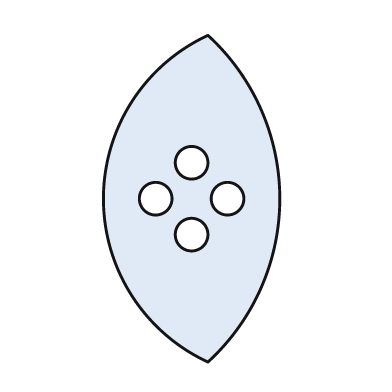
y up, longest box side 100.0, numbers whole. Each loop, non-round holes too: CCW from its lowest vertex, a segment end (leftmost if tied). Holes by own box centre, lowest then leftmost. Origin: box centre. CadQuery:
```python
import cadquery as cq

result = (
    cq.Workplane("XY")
    .moveTo(5.0, -50.0)
    .threePointArc((27.0, 0.0), (5.0, 50.0))
    .threePointArc((-27.0, 0.0), (5.0, -50.0))
    .close()
    .moveTo(0.0, -11.0)
    .circle(5.0)
    .moveTo(-11.0, 0.0)
    .circle(5.0)
    .moveTo(11.0, 0.0)
    .circle(5.0)
    .moveTo(0.0, 11.0)
    .circle(5.0)
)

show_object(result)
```